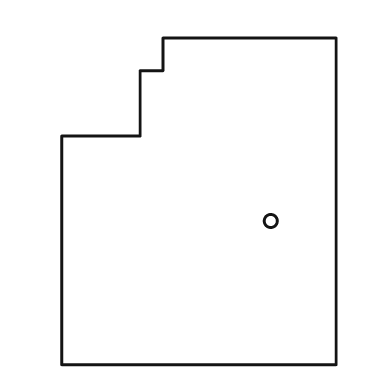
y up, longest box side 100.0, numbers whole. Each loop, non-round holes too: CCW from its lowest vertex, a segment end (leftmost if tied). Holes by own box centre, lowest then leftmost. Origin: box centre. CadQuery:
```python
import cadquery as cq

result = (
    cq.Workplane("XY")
    .moveTo(-42.0, -50.0)
    .lineTo(42.0, -50.0)
    .lineTo(42.0, 50.0)
    .lineTo(-11.0, 50.0)
    .lineTo(-11.0, 40.0)
    .lineTo(-18.0, 40.0)
    .lineTo(-18.0, 20.0)
    .lineTo(-42.0, 20.0)
    .close()
    .moveTo(22.0, -6.0)
    .circle(2.0)
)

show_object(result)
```